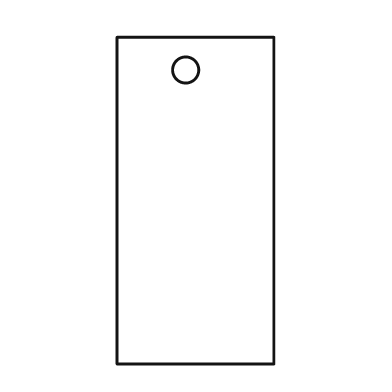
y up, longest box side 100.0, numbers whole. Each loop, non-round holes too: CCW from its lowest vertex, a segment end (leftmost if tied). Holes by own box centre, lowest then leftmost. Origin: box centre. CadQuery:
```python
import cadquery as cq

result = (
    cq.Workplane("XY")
    .moveTo(-24.0, -50.0)
    .lineTo(24.0, -50.0)
    .lineTo(24.0, 50.0)
    .lineTo(-24.0, 50.0)
    .close()
    .moveTo(-3.0, 40.0)
    .circle(4.0)
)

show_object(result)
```